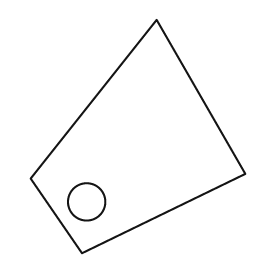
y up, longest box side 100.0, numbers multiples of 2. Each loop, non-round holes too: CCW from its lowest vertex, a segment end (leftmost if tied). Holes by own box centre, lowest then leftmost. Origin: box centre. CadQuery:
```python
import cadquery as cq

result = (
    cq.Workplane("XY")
    .moveTo(-24.0, -50.0)
    .lineTo(46.0, -16.0)
    .lineTo(8.0, 50.0)
    .lineTo(-46.0, -18.0)
    .close()
    .moveTo(-22.0, -28.0)
    .circle(8.0)
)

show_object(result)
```